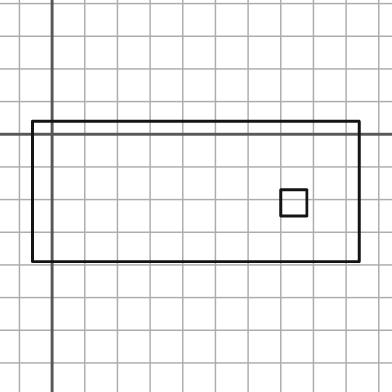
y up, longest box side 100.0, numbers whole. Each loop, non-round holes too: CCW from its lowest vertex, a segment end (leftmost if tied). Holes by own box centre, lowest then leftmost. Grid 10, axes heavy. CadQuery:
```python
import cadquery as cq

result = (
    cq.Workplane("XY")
    .moveTo(-6.0, -39.0)
    .lineTo(94.0, -39.0)
    .lineTo(94.0, 4.0)
    .lineTo(-6.0, 4.0)
    .close()
    .moveTo(70.0, -25.0)
    .lineTo(78.0, -25.0)
    .lineTo(78.0, -17.0)
    .lineTo(70.0, -17.0)
    .close()
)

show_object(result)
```